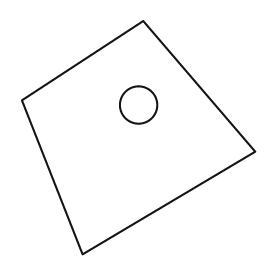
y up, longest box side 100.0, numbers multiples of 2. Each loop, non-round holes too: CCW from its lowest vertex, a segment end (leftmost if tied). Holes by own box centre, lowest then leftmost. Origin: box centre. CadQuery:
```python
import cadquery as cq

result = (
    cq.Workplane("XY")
    .moveTo(-24.0, -50.0)
    .lineTo(50.0, -6.0)
    .lineTo(2.0, 50.0)
    .lineTo(-50.0, 16.0)
    .close()
    .moveTo(0.0, 14.0)
    .circle(8.0)
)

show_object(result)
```